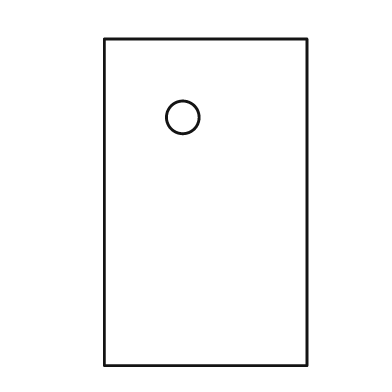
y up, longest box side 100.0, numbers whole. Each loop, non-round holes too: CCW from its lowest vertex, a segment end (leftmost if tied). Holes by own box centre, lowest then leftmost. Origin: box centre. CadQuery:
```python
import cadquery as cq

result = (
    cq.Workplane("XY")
    .moveTo(-31.0, -50.0)
    .lineTo(31.0, -50.0)
    .lineTo(31.0, 50.0)
    .lineTo(-31.0, 50.0)
    .close()
    .moveTo(-7.0, 26.0)
    .circle(5.0)
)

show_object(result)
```